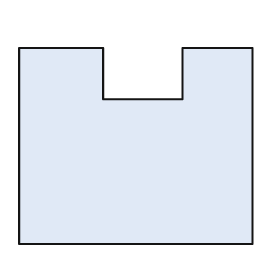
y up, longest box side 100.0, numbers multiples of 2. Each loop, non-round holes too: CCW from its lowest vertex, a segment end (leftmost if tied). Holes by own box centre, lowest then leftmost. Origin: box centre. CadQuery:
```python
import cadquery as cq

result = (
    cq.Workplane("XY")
    .moveTo(-50.0, -42.0)
    .lineTo(50.0, -42.0)
    .lineTo(50.0, 42.0)
    .lineTo(20.0, 42.0)
    .lineTo(20.0, 20.0)
    .lineTo(-14.0, 20.0)
    .lineTo(-14.0, 42.0)
    .lineTo(-50.0, 42.0)
    .close()
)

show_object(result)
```